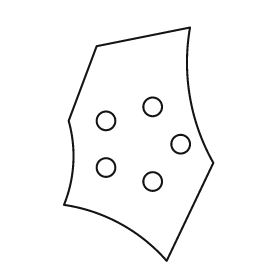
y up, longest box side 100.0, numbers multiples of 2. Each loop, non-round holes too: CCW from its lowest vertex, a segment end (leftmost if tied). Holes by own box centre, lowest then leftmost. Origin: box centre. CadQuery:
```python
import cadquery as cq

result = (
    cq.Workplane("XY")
    .moveTo(12.0, -50.0)
    .lineTo(32.0, -8.0)
    .threePointArc((22.0, 20.0), (22.0, 50.0))
    .lineTo(-18.0, 42.0)
    .lineTo(-30.0, 10.0)
    .threePointArc((-28.0, -8.0), (-32.0, -26.0))
    .threePointArc((-8.0, -34.0), (12.0, -50.0))
    .close()
    .moveTo(6.0, -16.0)
    .circle(4.0)
    .moveTo(-14.0, -10.0)
    .circle(4.0)
    .moveTo(18.0, 0.0)
    .circle(4.0)
    .moveTo(-14.0, 10.0)
    .circle(4.0)
    .moveTo(6.0, 16.0)
    .circle(4.0)
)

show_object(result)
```